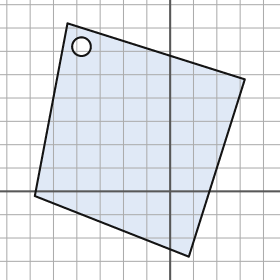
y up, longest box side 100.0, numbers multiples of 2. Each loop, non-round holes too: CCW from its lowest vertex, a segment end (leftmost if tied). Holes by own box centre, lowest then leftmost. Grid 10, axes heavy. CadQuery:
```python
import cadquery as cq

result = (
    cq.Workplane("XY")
    .moveTo(8.0, -28.0)
    .lineTo(32.0, 48.0)
    .lineTo(-44.0, 72.0)
    .lineTo(-58.0, -2.0)
    .close()
    .moveTo(-38.0, 62.0)
    .circle(4.0)
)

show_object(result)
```